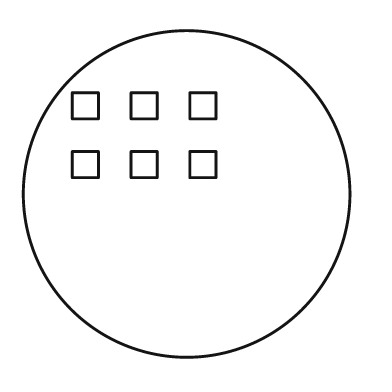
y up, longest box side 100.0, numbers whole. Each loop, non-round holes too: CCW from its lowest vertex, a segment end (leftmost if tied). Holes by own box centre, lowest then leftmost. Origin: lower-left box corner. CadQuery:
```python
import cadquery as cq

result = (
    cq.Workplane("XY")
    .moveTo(50.0, 50.0)
    .circle(50.0)
    .moveTo(15.0, 55.0)
    .lineTo(23.0, 55.0)
    .lineTo(23.0, 63.0)
    .lineTo(15.0, 63.0)
    .close()
    .moveTo(33.0, 55.0)
    .lineTo(41.0, 55.0)
    .lineTo(41.0, 63.0)
    .lineTo(33.0, 63.0)
    .close()
    .moveTo(51.0, 55.0)
    .lineTo(59.0, 55.0)
    .lineTo(59.0, 63.0)
    .lineTo(51.0, 63.0)
    .close()
    .moveTo(15.0, 73.0)
    .lineTo(23.0, 73.0)
    .lineTo(23.0, 81.0)
    .lineTo(15.0, 81.0)
    .close()
    .moveTo(33.0, 73.0)
    .lineTo(41.0, 73.0)
    .lineTo(41.0, 81.0)
    .lineTo(33.0, 81.0)
    .close()
    .moveTo(51.0, 73.0)
    .lineTo(59.0, 73.0)
    .lineTo(59.0, 81.0)
    .lineTo(51.0, 81.0)
    .close()
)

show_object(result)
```